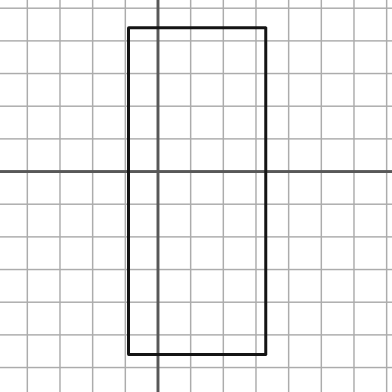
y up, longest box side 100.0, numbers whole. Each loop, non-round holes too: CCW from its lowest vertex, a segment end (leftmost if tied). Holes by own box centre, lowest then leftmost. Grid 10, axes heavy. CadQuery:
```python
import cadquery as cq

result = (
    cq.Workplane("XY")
    .moveTo(-9.0, -56.0)
    .lineTo(33.0, -56.0)
    .lineTo(33.0, 44.0)
    .lineTo(-9.0, 44.0)
    .close()
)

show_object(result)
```